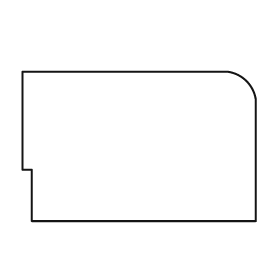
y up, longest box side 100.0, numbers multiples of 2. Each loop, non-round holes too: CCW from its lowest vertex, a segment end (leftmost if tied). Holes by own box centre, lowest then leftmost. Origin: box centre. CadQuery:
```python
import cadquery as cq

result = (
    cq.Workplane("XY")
    .moveTo(-46.0, -32.0)
    .lineTo(50.0, -32.0)
    .lineTo(50.0, 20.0)
    .threePointArc((46.0, 28.0), (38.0, 32.0))
    .lineTo(-50.0, 32.0)
    .lineTo(-50.0, -10.0)
    .lineTo(-46.0, -10.0)
    .close()
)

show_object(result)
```